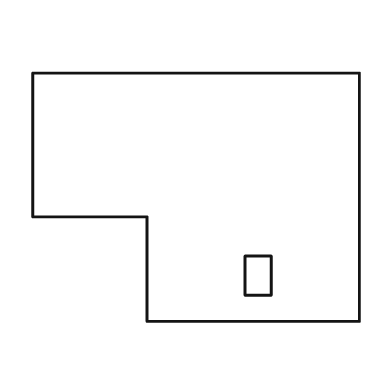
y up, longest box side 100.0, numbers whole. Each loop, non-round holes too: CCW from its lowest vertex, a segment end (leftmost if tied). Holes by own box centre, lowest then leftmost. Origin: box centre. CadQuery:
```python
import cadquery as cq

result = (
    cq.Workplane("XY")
    .moveTo(-15.0, -38.0)
    .lineTo(50.0, -38.0)
    .lineTo(50.0, 38.0)
    .lineTo(-50.0, 38.0)
    .lineTo(-50.0, -6.0)
    .lineTo(-15.0, -6.0)
    .close()
    .moveTo(15.0, -30.0)
    .lineTo(23.0, -30.0)
    .lineTo(23.0, -18.0)
    .lineTo(15.0, -18.0)
    .close()
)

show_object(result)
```